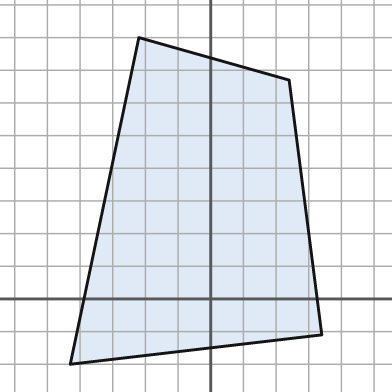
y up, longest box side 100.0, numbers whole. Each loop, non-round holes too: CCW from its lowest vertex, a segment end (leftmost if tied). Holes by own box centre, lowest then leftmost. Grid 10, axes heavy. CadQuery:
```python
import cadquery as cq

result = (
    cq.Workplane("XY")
    .moveTo(-43.0, -20.0)
    .lineTo(34.0, -11.0)
    .lineTo(24.0, 67.0)
    .lineTo(-22.0, 80.0)
    .close()
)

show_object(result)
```